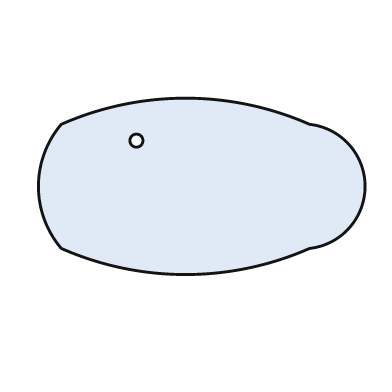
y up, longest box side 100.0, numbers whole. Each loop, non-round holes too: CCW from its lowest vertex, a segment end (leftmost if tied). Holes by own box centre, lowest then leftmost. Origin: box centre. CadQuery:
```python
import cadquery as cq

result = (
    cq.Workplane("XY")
    .moveTo(-43.0, -19.0)
    .threePointArc((-5.0, -27.0), (33.0, -19.0))
    .threePointArc((50.0, 0.0), (33.0, 19.0))
    .threePointArc((-5.0, 27.0), (-43.0, 19.0))
    .threePointArc((-50.0, 0.0), (-43.0, -19.0))
    .close()
    .moveTo(-20.0, 14.0)
    .circle(2.0)
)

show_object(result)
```